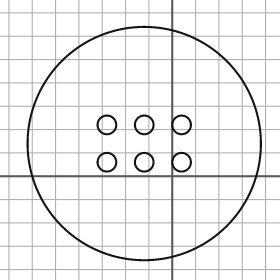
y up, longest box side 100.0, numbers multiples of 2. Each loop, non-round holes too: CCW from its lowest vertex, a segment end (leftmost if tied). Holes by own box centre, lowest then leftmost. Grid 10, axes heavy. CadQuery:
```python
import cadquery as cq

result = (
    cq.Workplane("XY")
    .moveTo(-12.0, 14.0)
    .circle(50.0)
    .moveTo(-28.0, 6.0)
    .circle(4.0)
    .moveTo(-12.0, 6.0)
    .circle(4.0)
    .moveTo(4.0, 6.0)
    .circle(4.0)
    .moveTo(-28.0, 22.0)
    .circle(4.0)
    .moveTo(-12.0, 22.0)
    .circle(4.0)
    .moveTo(4.0, 22.0)
    .circle(4.0)
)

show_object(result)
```